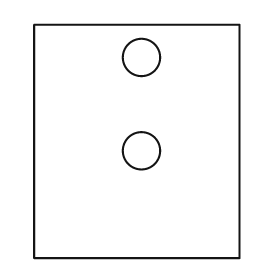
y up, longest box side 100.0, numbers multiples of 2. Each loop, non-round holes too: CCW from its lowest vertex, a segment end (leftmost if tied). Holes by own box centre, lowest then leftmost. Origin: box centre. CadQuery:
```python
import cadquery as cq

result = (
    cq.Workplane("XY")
    .moveTo(-44.0, -50.0)
    .lineTo(44.0, -50.0)
    .lineTo(44.0, 50.0)
    .lineTo(-44.0, 50.0)
    .close()
    .moveTo(2.0, -4.0)
    .circle(8.0)
    .moveTo(2.0, 36.0)
    .circle(8.0)
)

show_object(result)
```